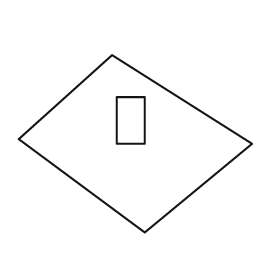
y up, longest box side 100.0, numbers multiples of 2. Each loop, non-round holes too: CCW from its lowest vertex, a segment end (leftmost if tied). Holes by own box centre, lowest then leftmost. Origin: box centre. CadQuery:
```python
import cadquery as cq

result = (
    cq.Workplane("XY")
    .moveTo(4.0, -38.0)
    .lineTo(50.0, 0.0)
    .lineTo(-10.0, 38.0)
    .lineTo(-50.0, 2.0)
    .close()
    .moveTo(-8.0, 0.0)
    .lineTo(4.0, 0.0)
    .lineTo(4.0, 20.0)
    .lineTo(-8.0, 20.0)
    .close()
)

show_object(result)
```